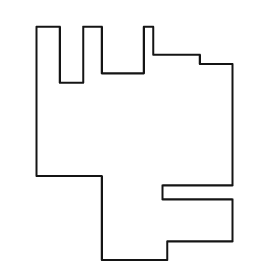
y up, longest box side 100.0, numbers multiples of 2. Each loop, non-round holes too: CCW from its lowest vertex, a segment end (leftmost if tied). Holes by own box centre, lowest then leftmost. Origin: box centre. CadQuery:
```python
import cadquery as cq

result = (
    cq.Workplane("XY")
    .moveTo(-14.0, -50.0)
    .lineTo(14.0, -50.0)
    .lineTo(14.0, -42.0)
    .lineTo(42.0, -42.0)
    .lineTo(42.0, -24.0)
    .lineTo(12.0, -24.0)
    .lineTo(12.0, -18.0)
    .lineTo(42.0, -18.0)
    .lineTo(42.0, 34.0)
    .lineTo(28.0, 34.0)
    .lineTo(28.0, 38.0)
    .lineTo(8.0, 38.0)
    .lineTo(8.0, 50.0)
    .lineTo(4.0, 50.0)
    .lineTo(4.0, 30.0)
    .lineTo(-14.0, 30.0)
    .lineTo(-14.0, 50.0)
    .lineTo(-22.0, 50.0)
    .lineTo(-22.0, 26.0)
    .lineTo(-32.0, 26.0)
    .lineTo(-32.0, 50.0)
    .lineTo(-42.0, 50.0)
    .lineTo(-42.0, -14.0)
    .lineTo(-14.0, -14.0)
    .close()
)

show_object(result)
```